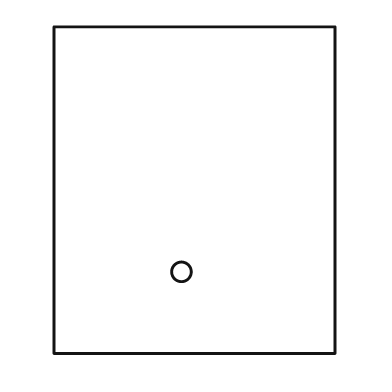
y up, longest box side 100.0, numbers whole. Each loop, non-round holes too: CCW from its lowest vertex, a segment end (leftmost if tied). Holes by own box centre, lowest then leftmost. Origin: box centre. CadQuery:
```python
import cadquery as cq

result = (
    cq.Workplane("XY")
    .moveTo(-43.0, -50.0)
    .lineTo(43.0, -50.0)
    .lineTo(43.0, 50.0)
    .lineTo(-43.0, 50.0)
    .close()
    .moveTo(-4.0, -25.0)
    .circle(3.0)
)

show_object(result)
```